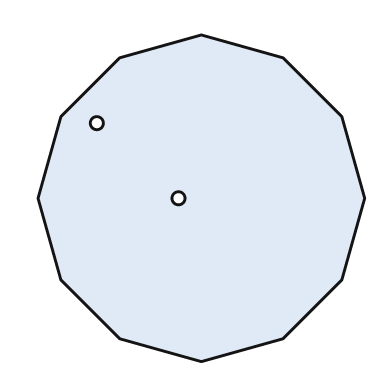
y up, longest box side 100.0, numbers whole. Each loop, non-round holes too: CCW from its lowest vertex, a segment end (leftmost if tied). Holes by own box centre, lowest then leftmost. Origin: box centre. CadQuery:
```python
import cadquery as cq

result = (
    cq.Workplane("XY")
    .moveTo(0.0, -50.0)
    .lineTo(25.0, -43.0)
    .lineTo(43.0, -25.0)
    .lineTo(50.0, 0.0)
    .lineTo(43.0, 25.0)
    .lineTo(25.0, 43.0)
    .lineTo(0.0, 50.0)
    .lineTo(-25.0, 43.0)
    .lineTo(-43.0, 25.0)
    .lineTo(-50.0, 0.0)
    .lineTo(-43.0, -25.0)
    .lineTo(-25.0, -43.0)
    .close()
    .moveTo(-7.0, 0.0)
    .circle(2.0)
    .moveTo(-32.0, 23.0)
    .circle(2.0)
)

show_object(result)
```